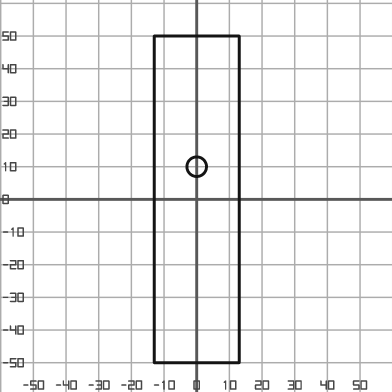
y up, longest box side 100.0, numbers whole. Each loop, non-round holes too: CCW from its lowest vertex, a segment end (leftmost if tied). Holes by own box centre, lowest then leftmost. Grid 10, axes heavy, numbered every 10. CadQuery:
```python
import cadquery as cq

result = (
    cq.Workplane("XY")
    .moveTo(-13.0, -50.0)
    .lineTo(13.0, -50.0)
    .lineTo(13.0, 50.0)
    .lineTo(-13.0, 50.0)
    .close()
    .moveTo(0.0, 10.0)
    .circle(3.0)
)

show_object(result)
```